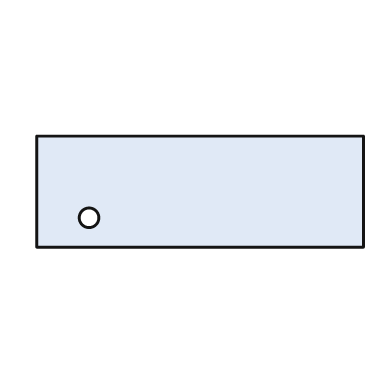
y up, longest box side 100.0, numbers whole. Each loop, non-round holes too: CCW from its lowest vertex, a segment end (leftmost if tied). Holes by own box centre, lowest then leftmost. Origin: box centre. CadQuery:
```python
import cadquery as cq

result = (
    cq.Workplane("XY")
    .moveTo(-50.0, -17.0)
    .lineTo(50.0, -17.0)
    .lineTo(50.0, 17.0)
    .lineTo(-50.0, 17.0)
    .close()
    .moveTo(-34.0, -8.0)
    .circle(3.0)
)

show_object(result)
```